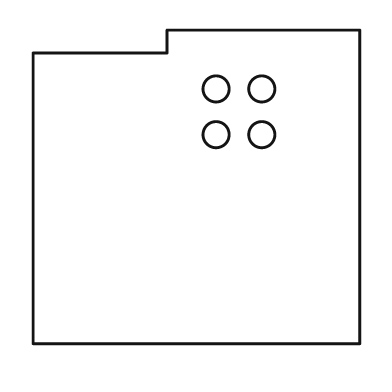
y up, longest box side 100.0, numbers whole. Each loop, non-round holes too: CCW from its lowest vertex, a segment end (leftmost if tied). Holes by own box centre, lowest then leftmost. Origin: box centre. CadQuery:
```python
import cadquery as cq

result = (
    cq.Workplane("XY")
    .moveTo(-50.0, -48.0)
    .lineTo(50.0, -48.0)
    .lineTo(50.0, 48.0)
    .lineTo(-9.0, 48.0)
    .lineTo(-9.0, 41.0)
    .lineTo(-50.0, 41.0)
    .close()
    .moveTo(6.0, 16.0)
    .circle(4.0)
    .moveTo(20.0, 16.0)
    .circle(4.0)
    .moveTo(6.0, 30.0)
    .circle(4.0)
    .moveTo(20.0, 30.0)
    .circle(4.0)
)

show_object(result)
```